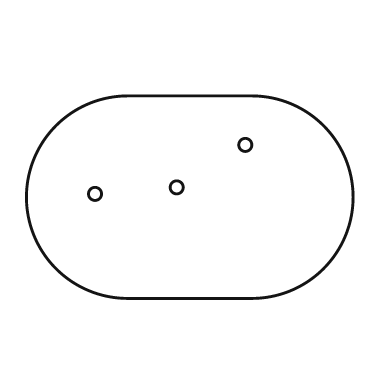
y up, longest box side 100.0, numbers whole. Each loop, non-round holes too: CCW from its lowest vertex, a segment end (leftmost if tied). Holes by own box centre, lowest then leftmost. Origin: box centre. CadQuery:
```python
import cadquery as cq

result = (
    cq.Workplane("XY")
    .moveTo(-19.0, -31.0)
    .lineTo(19.0, -31.0)
    .threePointArc((50.0, 0.0), (19.0, 31.0))
    .lineTo(-19.0, 31.0)
    .threePointArc((-50.0, 0.0), (-19.0, -31.0))
    .close()
    .moveTo(-29.0, 1.0)
    .circle(2.0)
    .moveTo(-4.0, 3.0)
    .circle(2.0)
    .moveTo(17.0, 16.0)
    .circle(2.0)
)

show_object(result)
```